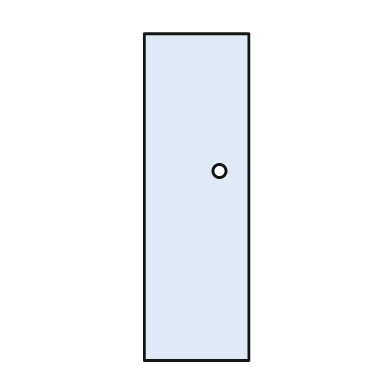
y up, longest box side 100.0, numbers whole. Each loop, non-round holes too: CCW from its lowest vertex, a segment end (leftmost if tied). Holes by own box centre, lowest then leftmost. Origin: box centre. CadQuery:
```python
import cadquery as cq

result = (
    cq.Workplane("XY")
    .moveTo(-16.0, -50.0)
    .lineTo(16.0, -50.0)
    .lineTo(16.0, 50.0)
    .lineTo(-16.0, 50.0)
    .close()
    .moveTo(7.0, 8.0)
    .circle(2.0)
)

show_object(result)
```